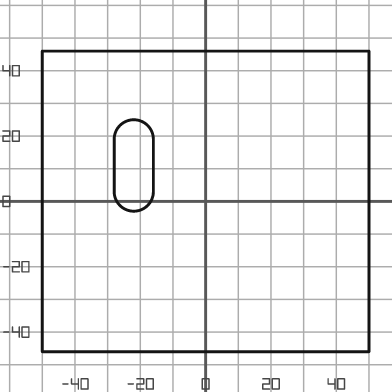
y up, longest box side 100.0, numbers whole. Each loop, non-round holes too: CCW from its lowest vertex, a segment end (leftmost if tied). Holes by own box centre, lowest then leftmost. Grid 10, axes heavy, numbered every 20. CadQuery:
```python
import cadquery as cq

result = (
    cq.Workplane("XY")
    .moveTo(-50.0, -46.0)
    .lineTo(50.0, -46.0)
    .lineTo(50.0, 46.0)
    .lineTo(-50.0, 46.0)
    .close()
    .moveTo(-28.0, 3.0)
    .threePointArc((-22.0, -3.0), (-16.0, 3.0))
    .lineTo(-16.0, 19.0)
    .threePointArc((-22.0, 25.0), (-28.0, 19.0))
    .close()
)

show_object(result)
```